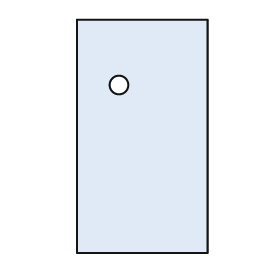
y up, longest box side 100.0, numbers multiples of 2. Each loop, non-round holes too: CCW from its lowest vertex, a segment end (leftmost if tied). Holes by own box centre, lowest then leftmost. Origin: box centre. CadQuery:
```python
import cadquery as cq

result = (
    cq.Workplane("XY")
    .moveTo(-28.0, -50.0)
    .lineTo(28.0, -50.0)
    .lineTo(28.0, 50.0)
    .lineTo(-28.0, 50.0)
    .close()
    .moveTo(-10.0, 22.0)
    .circle(4.0)
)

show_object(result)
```